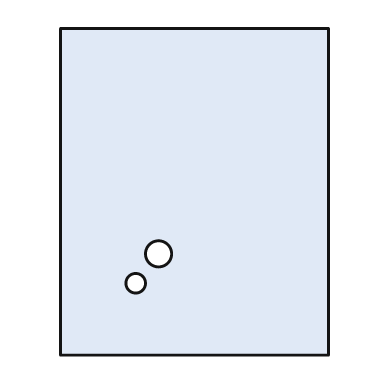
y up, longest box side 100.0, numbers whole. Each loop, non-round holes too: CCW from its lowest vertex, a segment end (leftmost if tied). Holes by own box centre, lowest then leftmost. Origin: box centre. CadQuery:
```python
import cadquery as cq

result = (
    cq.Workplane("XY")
    .moveTo(-41.0, -50.0)
    .lineTo(41.0, -50.0)
    .lineTo(41.0, 50.0)
    .lineTo(-41.0, 50.0)
    .close()
    .moveTo(-18.0, -28.0)
    .circle(3.0)
    .moveTo(-11.0, -19.0)
    .circle(4.0)
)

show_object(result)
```